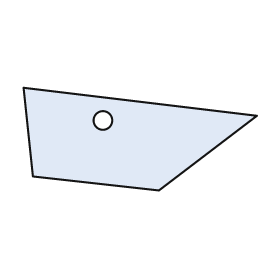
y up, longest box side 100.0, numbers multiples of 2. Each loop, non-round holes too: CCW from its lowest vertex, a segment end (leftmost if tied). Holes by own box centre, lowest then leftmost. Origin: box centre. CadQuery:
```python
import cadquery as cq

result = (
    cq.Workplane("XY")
    .moveTo(8.0, -22.0)
    .lineTo(50.0, 10.0)
    .lineTo(-50.0, 22.0)
    .lineTo(-46.0, -16.0)
    .close()
    .moveTo(-16.0, 8.0)
    .circle(4.0)
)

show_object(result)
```